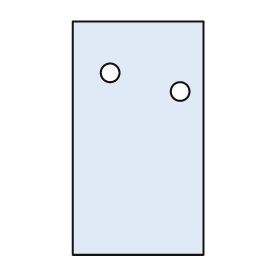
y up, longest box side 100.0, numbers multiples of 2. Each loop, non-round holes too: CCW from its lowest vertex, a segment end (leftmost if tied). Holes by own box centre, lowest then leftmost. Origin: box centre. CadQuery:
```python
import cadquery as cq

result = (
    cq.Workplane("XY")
    .moveTo(-28.0, -50.0)
    .lineTo(28.0, -50.0)
    .lineTo(28.0, 50.0)
    .lineTo(-28.0, 50.0)
    .close()
    .moveTo(18.0, 20.0)
    .circle(4.0)
    .moveTo(-12.0, 28.0)
    .circle(4.0)
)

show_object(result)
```